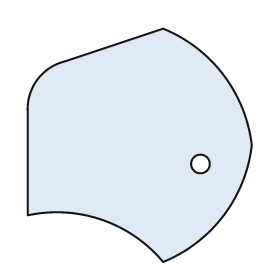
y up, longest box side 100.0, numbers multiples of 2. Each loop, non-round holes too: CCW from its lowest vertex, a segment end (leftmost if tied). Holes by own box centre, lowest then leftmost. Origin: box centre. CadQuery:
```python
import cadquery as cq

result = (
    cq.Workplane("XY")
    .moveTo(10.0, -50.0)
    .threePointArc((36.0, -30.0), (48.0, 0.0))
    .threePointArc((36.0, 30.0), (10.0, 50.0))
    .lineTo(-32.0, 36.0)
    .threePointArc((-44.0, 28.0), (-48.0, 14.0))
    .lineTo(-48.0, -30.0)
    .threePointArc((-16.0, -32.0), (10.0, -50.0))
    .close()
    .moveTo(26.0, -8.0)
    .circle(4.0)
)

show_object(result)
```